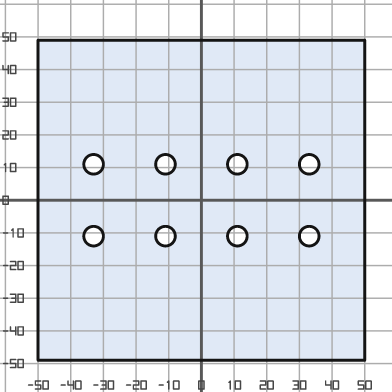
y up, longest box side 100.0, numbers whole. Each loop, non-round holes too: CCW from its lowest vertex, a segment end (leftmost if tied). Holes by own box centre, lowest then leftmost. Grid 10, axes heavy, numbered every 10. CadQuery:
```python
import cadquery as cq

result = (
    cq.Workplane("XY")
    .moveTo(-50.0, -49.0)
    .lineTo(50.0, -49.0)
    .lineTo(50.0, 49.0)
    .lineTo(-50.0, 49.0)
    .close()
    .moveTo(-33.0, -11.0)
    .circle(3.0)
    .moveTo(-11.0, -11.0)
    .circle(3.0)
    .moveTo(11.0, -11.0)
    .circle(3.0)
    .moveTo(33.0, -11.0)
    .circle(3.0)
    .moveTo(-33.0, 11.0)
    .circle(3.0)
    .moveTo(-11.0, 11.0)
    .circle(3.0)
    .moveTo(11.0, 11.0)
    .circle(3.0)
    .moveTo(33.0, 11.0)
    .circle(3.0)
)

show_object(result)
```